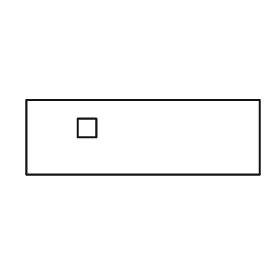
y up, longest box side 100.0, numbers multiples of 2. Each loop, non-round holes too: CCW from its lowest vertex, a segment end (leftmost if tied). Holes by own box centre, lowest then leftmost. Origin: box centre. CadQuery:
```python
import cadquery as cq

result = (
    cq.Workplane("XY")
    .moveTo(-50.0, -16.0)
    .lineTo(50.0, -16.0)
    .lineTo(50.0, 16.0)
    .lineTo(-50.0, 16.0)
    .close()
    .moveTo(-28.0, 0.0)
    .lineTo(-20.0, 0.0)
    .lineTo(-20.0, 8.0)
    .lineTo(-28.0, 8.0)
    .close()
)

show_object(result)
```